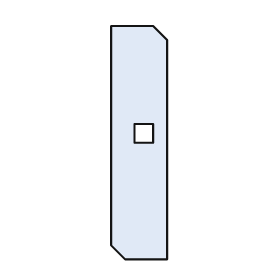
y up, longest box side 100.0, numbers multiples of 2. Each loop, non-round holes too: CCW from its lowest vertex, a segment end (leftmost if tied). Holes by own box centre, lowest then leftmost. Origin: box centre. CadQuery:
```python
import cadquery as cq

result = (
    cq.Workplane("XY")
    .moveTo(-6.0, -50.0)
    .lineTo(12.0, -50.0)
    .lineTo(12.0, 44.0)
    .lineTo(6.0, 50.0)
    .lineTo(-12.0, 50.0)
    .lineTo(-12.0, -44.0)
    .close()
    .moveTo(-2.0, 0.0)
    .lineTo(6.0, 0.0)
    .lineTo(6.0, 8.0)
    .lineTo(-2.0, 8.0)
    .close()
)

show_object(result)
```